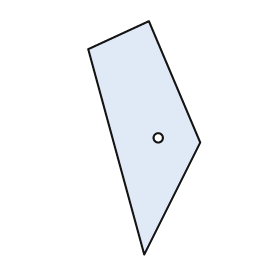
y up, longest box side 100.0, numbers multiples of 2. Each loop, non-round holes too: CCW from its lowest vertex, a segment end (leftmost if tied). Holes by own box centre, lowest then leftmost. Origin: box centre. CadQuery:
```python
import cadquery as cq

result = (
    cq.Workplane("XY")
    .moveTo(0.0, -50.0)
    .lineTo(24.0, -2.0)
    .lineTo(2.0, 50.0)
    .lineTo(-24.0, 38.0)
    .close()
    .moveTo(6.0, 0.0)
    .circle(2.0)
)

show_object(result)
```